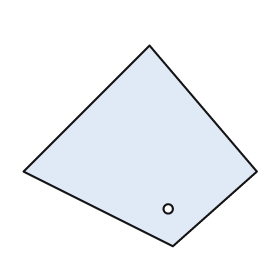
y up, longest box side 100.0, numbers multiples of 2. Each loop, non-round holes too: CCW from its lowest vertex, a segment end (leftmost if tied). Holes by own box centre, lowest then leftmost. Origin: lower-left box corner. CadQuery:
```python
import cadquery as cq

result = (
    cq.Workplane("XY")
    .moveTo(64.0, 0.0)
    .lineTo(100.0, 32.0)
    .lineTo(54.0, 86.0)
    .lineTo(0.0, 32.0)
    .close()
    .moveTo(62.0, 16.0)
    .circle(2.0)
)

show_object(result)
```